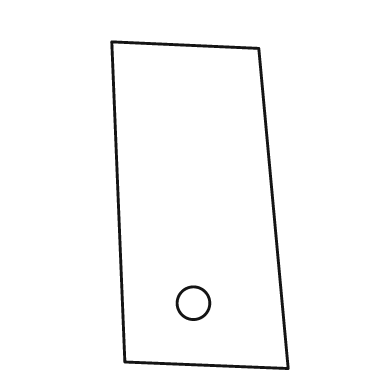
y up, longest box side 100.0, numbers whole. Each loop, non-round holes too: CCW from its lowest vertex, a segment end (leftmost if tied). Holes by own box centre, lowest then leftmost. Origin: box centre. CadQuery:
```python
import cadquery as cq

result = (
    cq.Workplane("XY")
    .moveTo(27.0, -50.0)
    .lineTo(18.0, 48.0)
    .lineTo(-27.0, 50.0)
    .lineTo(-23.0, -48.0)
    .close()
    .moveTo(-2.0, -30.0)
    .circle(5.0)
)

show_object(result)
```